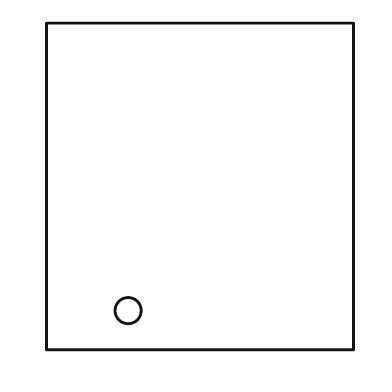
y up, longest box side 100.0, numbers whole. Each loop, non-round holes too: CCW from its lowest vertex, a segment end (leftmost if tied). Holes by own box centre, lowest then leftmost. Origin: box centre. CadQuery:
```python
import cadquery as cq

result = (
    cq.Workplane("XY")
    .moveTo(-47.0, -50.0)
    .lineTo(47.0, -50.0)
    .lineTo(47.0, 50.0)
    .lineTo(-47.0, 50.0)
    .close()
    .moveTo(-22.0, -38.0)
    .circle(4.0)
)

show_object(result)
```